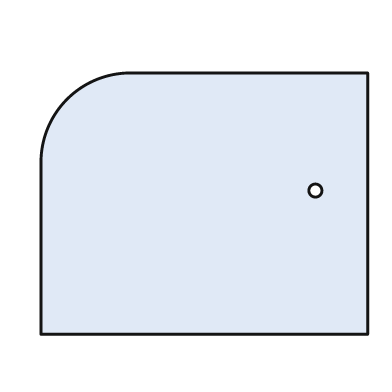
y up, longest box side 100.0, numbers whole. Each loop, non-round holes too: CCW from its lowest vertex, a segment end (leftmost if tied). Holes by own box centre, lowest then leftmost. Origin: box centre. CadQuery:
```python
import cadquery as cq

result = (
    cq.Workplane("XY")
    .moveTo(-50.0, -40.0)
    .lineTo(50.0, -40.0)
    .lineTo(50.0, 40.0)
    .lineTo(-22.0, 40.0)
    .threePointArc((-42.0, 32.0), (-50.0, 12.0))
    .close()
    .moveTo(34.0, 4.0)
    .circle(2.0)
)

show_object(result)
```